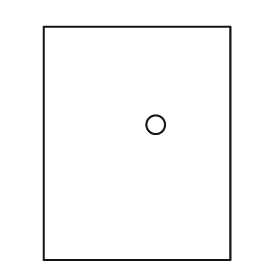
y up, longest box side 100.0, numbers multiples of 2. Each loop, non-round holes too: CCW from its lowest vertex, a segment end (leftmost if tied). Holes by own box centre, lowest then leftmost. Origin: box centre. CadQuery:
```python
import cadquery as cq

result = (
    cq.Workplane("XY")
    .moveTo(-40.0, -50.0)
    .lineTo(40.0, -50.0)
    .lineTo(40.0, 50.0)
    .lineTo(-40.0, 50.0)
    .close()
    .moveTo(8.0, 8.0)
    .circle(4.0)
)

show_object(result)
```